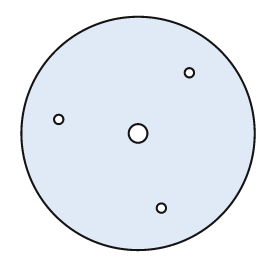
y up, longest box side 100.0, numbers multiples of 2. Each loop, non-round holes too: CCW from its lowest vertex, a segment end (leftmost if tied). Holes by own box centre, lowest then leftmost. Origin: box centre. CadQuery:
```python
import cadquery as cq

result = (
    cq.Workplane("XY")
    .moveTo(0.0, 0.0)
    .circle(50.0)
    .moveTo(10.0, -32.0)
    .circle(2.0)
    .moveTo(0.0, 0.0)
    .circle(4.0)
    .moveTo(-34.0, 6.0)
    .circle(2.0)
    .moveTo(22.0, 26.0)
    .circle(2.0)
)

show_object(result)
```